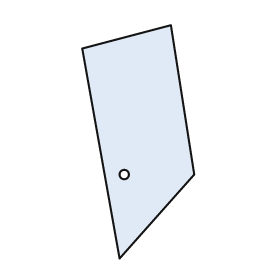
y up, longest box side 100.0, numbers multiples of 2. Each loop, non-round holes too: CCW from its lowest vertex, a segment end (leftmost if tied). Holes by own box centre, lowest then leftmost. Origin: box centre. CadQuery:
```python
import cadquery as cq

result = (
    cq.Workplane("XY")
    .moveTo(-8.0, -50.0)
    .lineTo(24.0, -14.0)
    .lineTo(14.0, 50.0)
    .lineTo(-24.0, 40.0)
    .close()
    .moveTo(-6.0, -14.0)
    .circle(2.0)
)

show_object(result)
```